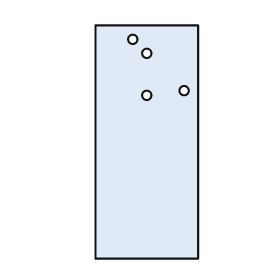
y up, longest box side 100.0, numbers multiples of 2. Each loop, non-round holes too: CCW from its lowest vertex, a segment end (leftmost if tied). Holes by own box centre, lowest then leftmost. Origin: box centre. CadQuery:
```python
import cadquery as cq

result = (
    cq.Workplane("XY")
    .moveTo(-22.0, -50.0)
    .lineTo(22.0, -50.0)
    .lineTo(22.0, 50.0)
    .lineTo(-22.0, 50.0)
    .close()
    .moveTo(0.0, 20.0)
    .circle(2.0)
    .moveTo(16.0, 22.0)
    .circle(2.0)
    .moveTo(0.0, 38.0)
    .circle(2.0)
    .moveTo(-6.0, 44.0)
    .circle(2.0)
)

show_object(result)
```